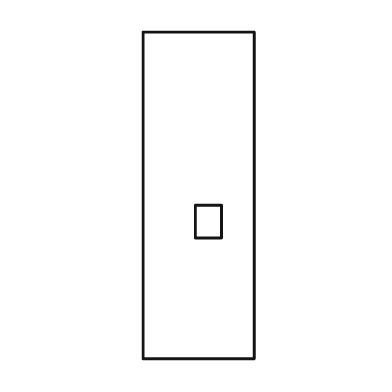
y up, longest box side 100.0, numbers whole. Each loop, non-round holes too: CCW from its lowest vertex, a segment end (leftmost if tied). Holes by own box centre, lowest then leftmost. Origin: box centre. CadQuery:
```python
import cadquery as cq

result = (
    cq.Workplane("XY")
    .moveTo(-17.0, -50.0)
    .lineTo(17.0, -50.0)
    .lineTo(17.0, 50.0)
    .lineTo(-17.0, 50.0)
    .close()
    .moveTo(-1.0, -13.0)
    .lineTo(7.0, -13.0)
    .lineTo(7.0, -3.0)
    .lineTo(-1.0, -3.0)
    .close()
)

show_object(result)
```